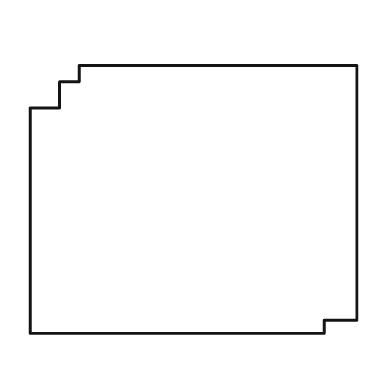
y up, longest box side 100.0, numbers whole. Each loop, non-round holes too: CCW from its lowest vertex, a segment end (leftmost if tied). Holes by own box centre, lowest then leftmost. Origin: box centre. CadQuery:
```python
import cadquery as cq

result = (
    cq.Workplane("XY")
    .moveTo(-50.0, -41.0)
    .lineTo(40.0, -41.0)
    .lineTo(40.0, -37.0)
    .lineTo(50.0, -37.0)
    .lineTo(50.0, 41.0)
    .lineTo(-35.0, 41.0)
    .lineTo(-35.0, 36.0)
    .lineTo(-41.0, 36.0)
    .lineTo(-41.0, 28.0)
    .lineTo(-50.0, 28.0)
    .close()
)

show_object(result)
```